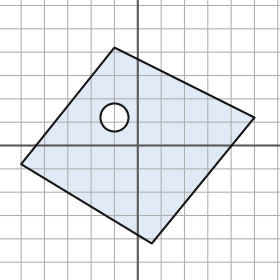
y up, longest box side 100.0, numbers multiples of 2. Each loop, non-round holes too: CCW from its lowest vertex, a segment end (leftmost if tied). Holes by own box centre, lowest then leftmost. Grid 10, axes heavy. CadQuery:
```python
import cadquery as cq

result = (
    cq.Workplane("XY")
    .moveTo(6.0, -42.0)
    .lineTo(50.0, 12.0)
    .lineTo(-10.0, 42.0)
    .lineTo(-50.0, -8.0)
    .close()
    .moveTo(-10.0, 12.0)
    .circle(6.0)
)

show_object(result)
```